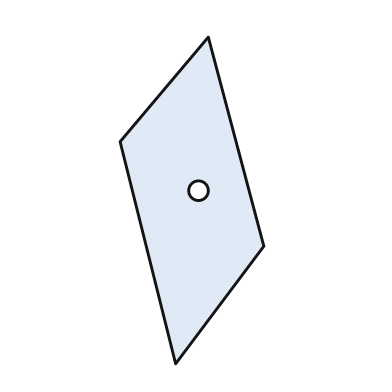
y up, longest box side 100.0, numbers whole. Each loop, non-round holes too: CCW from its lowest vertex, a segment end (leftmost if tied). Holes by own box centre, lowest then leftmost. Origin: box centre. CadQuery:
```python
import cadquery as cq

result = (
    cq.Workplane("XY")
    .moveTo(-5.0, -50.0)
    .lineTo(22.0, -14.0)
    .lineTo(5.0, 50.0)
    .lineTo(-22.0, 18.0)
    .close()
    .moveTo(2.0, 3.0)
    .circle(3.0)
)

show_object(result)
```